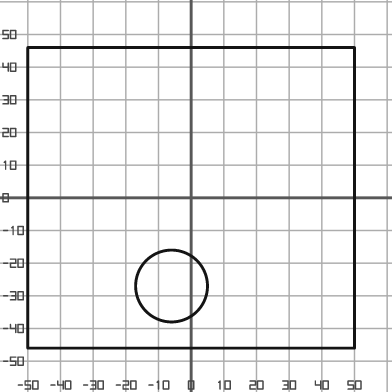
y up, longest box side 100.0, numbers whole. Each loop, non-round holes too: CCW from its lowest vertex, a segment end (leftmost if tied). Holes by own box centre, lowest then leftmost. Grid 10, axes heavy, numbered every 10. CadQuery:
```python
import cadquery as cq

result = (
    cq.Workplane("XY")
    .moveTo(-50.0, -46.0)
    .lineTo(50.0, -46.0)
    .lineTo(50.0, 46.0)
    .lineTo(-50.0, 46.0)
    .close()
    .moveTo(-6.0, -27.0)
    .circle(11.0)
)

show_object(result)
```